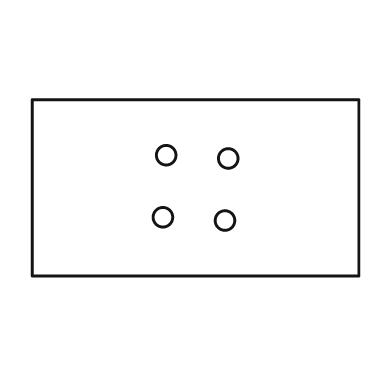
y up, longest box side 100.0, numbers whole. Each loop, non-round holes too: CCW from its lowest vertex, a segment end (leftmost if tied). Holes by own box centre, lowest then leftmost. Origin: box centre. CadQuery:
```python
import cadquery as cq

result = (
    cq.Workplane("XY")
    .moveTo(-50.0, -27.0)
    .lineTo(50.0, -27.0)
    .lineTo(50.0, 27.0)
    .lineTo(-50.0, 27.0)
    .close()
    .moveTo(9.0, -10.0)
    .circle(3.0)
    .moveTo(-10.0, -9.0)
    .circle(3.0)
    .moveTo(10.0, 9.0)
    .circle(3.0)
    .moveTo(-9.0, 10.0)
    .circle(3.0)
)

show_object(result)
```